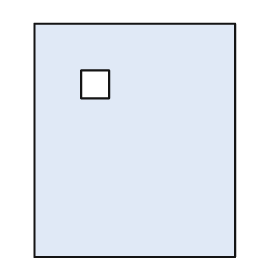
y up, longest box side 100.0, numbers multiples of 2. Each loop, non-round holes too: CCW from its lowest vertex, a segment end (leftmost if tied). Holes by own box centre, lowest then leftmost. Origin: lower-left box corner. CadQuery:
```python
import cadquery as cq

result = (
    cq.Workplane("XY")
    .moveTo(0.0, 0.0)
    .lineTo(86.0, 0.0)
    .lineTo(86.0, 100.0)
    .lineTo(0.0, 100.0)
    .close()
    .moveTo(20.0, 68.0)
    .lineTo(32.0, 68.0)
    .lineTo(32.0, 80.0)
    .lineTo(20.0, 80.0)
    .close()
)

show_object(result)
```